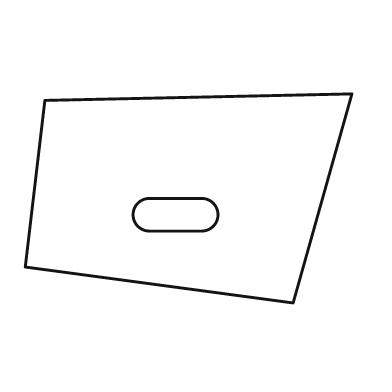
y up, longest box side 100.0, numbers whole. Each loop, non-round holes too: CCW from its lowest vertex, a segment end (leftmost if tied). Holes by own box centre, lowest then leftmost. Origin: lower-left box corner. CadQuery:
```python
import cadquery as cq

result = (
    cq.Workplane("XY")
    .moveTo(82.0, 0.0)
    .lineTo(100.0, 64.0)
    .lineTo(6.0, 62.0)
    .lineTo(0.0, 11.0)
    .close()
    .moveTo(38.0, 22.0)
    .lineTo(54.0, 22.0)
    .threePointArc((59.0, 27.0), (54.0, 32.0))
    .lineTo(38.0, 32.0)
    .threePointArc((33.0, 27.0), (38.0, 22.0))
    .close()
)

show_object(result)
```